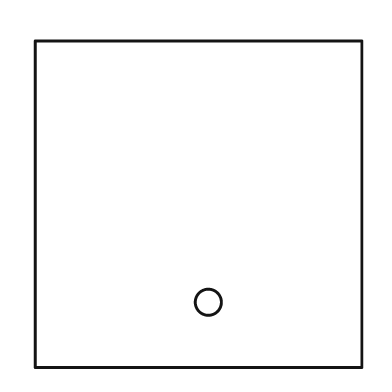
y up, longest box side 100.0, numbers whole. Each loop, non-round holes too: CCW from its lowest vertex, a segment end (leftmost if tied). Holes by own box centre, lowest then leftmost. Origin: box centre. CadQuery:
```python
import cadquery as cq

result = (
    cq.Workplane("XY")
    .moveTo(-50.0, -50.0)
    .lineTo(50.0, -50.0)
    .lineTo(50.0, 50.0)
    .lineTo(-50.0, 50.0)
    .close()
    .moveTo(3.0, -30.0)
    .circle(4.0)
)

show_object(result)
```